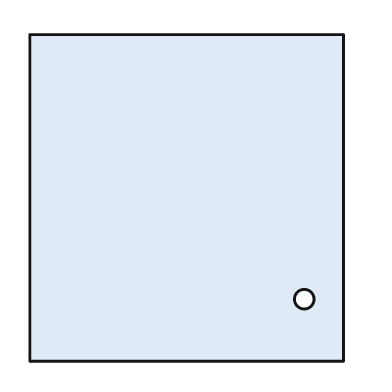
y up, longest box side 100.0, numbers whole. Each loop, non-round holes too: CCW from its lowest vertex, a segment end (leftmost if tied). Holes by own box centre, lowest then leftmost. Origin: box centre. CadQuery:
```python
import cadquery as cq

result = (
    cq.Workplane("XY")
    .moveTo(-48.0, -50.0)
    .lineTo(48.0, -50.0)
    .lineTo(48.0, 50.0)
    .lineTo(-48.0, 50.0)
    .close()
    .moveTo(36.0, -31.0)
    .circle(3.0)
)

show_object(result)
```